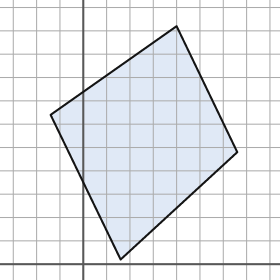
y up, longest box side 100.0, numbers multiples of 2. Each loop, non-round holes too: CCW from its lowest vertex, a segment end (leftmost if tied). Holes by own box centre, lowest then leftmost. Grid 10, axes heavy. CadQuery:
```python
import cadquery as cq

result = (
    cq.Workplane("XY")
    .moveTo(16.0, 2.0)
    .lineTo(66.0, 48.0)
    .lineTo(40.0, 102.0)
    .lineTo(-14.0, 64.0)
    .close()
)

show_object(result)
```